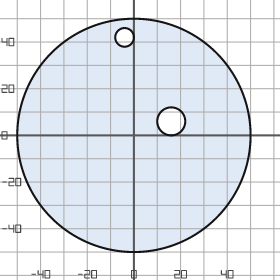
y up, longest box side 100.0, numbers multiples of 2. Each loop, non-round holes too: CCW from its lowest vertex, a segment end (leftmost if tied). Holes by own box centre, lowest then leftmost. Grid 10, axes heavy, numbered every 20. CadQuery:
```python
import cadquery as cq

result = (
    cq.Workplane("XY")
    .moveTo(0.0, 0.0)
    .circle(50.0)
    .moveTo(16.0, 6.0)
    .circle(6.0)
    .moveTo(-4.0, 42.0)
    .circle(4.0)
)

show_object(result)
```